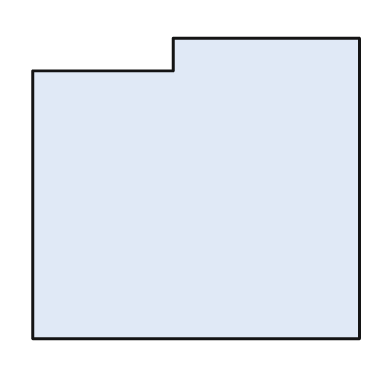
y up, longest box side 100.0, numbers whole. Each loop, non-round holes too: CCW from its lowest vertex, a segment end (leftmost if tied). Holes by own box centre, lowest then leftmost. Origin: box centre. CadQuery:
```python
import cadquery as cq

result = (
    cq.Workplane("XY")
    .moveTo(-50.0, -46.0)
    .lineTo(50.0, -46.0)
    .lineTo(50.0, 46.0)
    .lineTo(-7.0, 46.0)
    .lineTo(-7.0, 36.0)
    .lineTo(-50.0, 36.0)
    .close()
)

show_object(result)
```